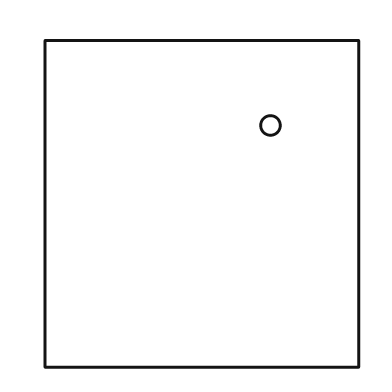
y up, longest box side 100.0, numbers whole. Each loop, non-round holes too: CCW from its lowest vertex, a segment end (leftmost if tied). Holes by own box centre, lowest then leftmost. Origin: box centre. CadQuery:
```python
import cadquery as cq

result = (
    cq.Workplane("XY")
    .moveTo(-48.0, -50.0)
    .lineTo(48.0, -50.0)
    .lineTo(48.0, 50.0)
    .lineTo(-48.0, 50.0)
    .close()
    .moveTo(21.0, 24.0)
    .circle(3.0)
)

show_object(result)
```